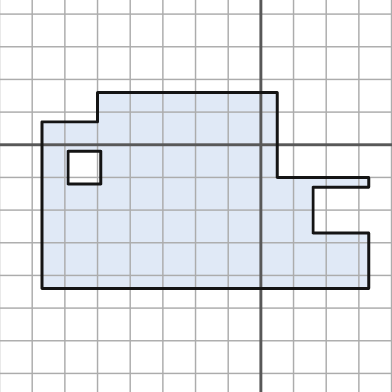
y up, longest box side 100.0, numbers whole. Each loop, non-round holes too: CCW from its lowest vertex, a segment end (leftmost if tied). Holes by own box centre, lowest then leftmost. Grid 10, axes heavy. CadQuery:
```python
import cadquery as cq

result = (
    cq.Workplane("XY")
    .moveTo(-67.0, -44.0)
    .lineTo(33.0, -44.0)
    .lineTo(33.0, -27.0)
    .lineTo(16.0, -27.0)
    .lineTo(16.0, -13.0)
    .lineTo(33.0, -13.0)
    .lineTo(33.0, -10.0)
    .lineTo(5.0, -10.0)
    .lineTo(5.0, 16.0)
    .lineTo(-50.0, 16.0)
    .lineTo(-50.0, 7.0)
    .lineTo(-67.0, 7.0)
    .close()
    .moveTo(-59.0, -12.0)
    .lineTo(-49.0, -12.0)
    .lineTo(-49.0, -2.0)
    .lineTo(-59.0, -2.0)
    .close()
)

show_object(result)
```